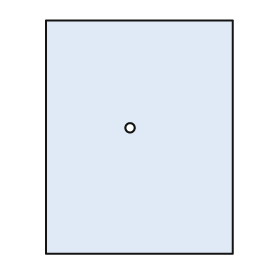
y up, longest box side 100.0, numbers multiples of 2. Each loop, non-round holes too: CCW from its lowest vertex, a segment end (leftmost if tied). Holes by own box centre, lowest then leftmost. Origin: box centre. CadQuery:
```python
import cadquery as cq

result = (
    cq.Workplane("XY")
    .moveTo(-40.0, -50.0)
    .lineTo(40.0, -50.0)
    .lineTo(40.0, 50.0)
    .lineTo(-40.0, 50.0)
    .close()
    .moveTo(-4.0, 4.0)
    .circle(2.0)
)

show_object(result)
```